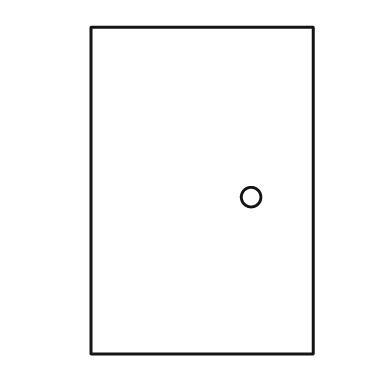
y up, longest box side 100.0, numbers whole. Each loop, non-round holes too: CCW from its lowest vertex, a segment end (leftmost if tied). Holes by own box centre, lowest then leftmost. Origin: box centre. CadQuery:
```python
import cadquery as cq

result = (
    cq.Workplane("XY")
    .moveTo(-34.0, -50.0)
    .lineTo(34.0, -50.0)
    .lineTo(34.0, 50.0)
    .lineTo(-34.0, 50.0)
    .close()
    .moveTo(15.0, -2.0)
    .circle(3.0)
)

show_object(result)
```